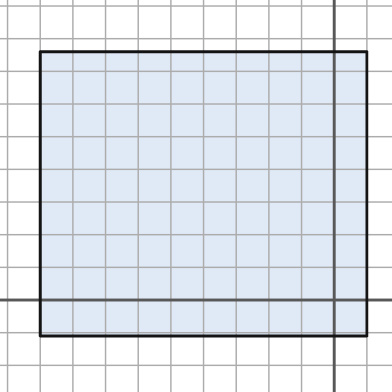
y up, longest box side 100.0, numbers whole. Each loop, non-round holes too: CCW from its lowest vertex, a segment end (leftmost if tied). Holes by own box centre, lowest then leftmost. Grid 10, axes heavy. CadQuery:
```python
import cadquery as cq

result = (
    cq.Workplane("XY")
    .moveTo(-90.0, -11.0)
    .lineTo(10.0, -11.0)
    .lineTo(10.0, 76.0)
    .lineTo(-90.0, 76.0)
    .close()
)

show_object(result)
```